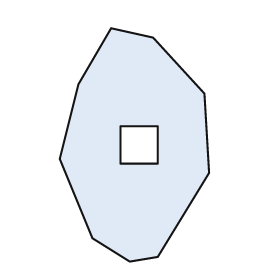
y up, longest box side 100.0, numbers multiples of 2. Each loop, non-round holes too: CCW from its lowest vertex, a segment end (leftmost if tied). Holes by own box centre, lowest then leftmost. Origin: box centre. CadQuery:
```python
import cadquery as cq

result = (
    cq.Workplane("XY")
    .moveTo(-2.0, -50.0)
    .lineTo(10.0, -48.0)
    .lineTo(32.0, -12.0)
    .lineTo(30.0, 22.0)
    .lineTo(8.0, 46.0)
    .lineTo(-10.0, 50.0)
    .lineTo(-24.0, 26.0)
    .lineTo(-32.0, -6.0)
    .lineTo(-18.0, -40.0)
    .close()
    .moveTo(-6.0, -8.0)
    .lineTo(10.0, -8.0)
    .lineTo(10.0, 8.0)
    .lineTo(-6.0, 8.0)
    .close()
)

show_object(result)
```